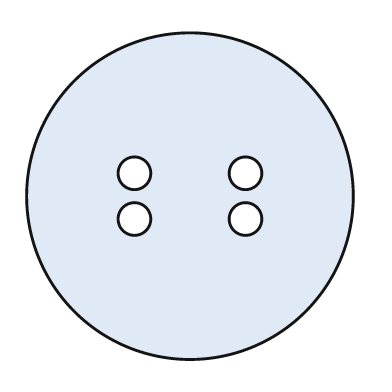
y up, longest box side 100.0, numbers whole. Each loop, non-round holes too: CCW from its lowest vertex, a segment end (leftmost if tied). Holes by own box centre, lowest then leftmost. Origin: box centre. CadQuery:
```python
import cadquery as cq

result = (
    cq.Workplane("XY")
    .moveTo(0.0, 0.0)
    .circle(50.0)
    .moveTo(-17.0, -7.0)
    .circle(5.0)
    .moveTo(17.0, -7.0)
    .circle(5.0)
    .moveTo(-17.0, 7.0)
    .circle(5.0)
    .moveTo(17.0, 7.0)
    .circle(5.0)
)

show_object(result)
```